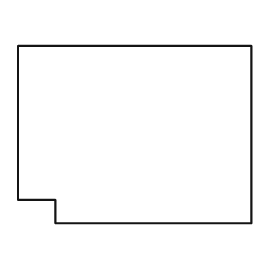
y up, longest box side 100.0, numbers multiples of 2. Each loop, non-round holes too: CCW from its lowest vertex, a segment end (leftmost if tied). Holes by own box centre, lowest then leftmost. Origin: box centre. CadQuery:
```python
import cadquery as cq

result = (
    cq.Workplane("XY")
    .moveTo(-34.0, -38.0)
    .lineTo(50.0, -38.0)
    .lineTo(50.0, 38.0)
    .lineTo(-50.0, 38.0)
    .lineTo(-50.0, -28.0)
    .lineTo(-34.0, -28.0)
    .close()
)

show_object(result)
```